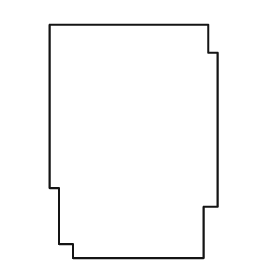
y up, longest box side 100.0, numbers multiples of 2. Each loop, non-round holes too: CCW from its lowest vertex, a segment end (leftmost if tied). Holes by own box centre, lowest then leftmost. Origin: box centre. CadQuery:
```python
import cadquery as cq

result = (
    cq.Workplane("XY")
    .moveTo(-26.0, -50.0)
    .lineTo(30.0, -50.0)
    .lineTo(30.0, -28.0)
    .lineTo(36.0, -28.0)
    .lineTo(36.0, 38.0)
    .lineTo(32.0, 38.0)
    .lineTo(32.0, 50.0)
    .lineTo(-36.0, 50.0)
    .lineTo(-36.0, -20.0)
    .lineTo(-32.0, -20.0)
    .lineTo(-32.0, -44.0)
    .lineTo(-26.0, -44.0)
    .close()
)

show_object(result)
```